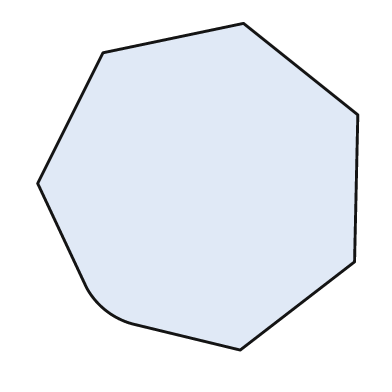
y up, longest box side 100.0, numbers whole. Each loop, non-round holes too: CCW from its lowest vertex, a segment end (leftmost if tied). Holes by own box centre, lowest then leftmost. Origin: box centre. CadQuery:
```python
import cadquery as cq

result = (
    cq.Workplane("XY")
    .moveTo(13.0, -50.0)
    .lineTo(48.0, -23.0)
    .lineTo(49.0, 22.0)
    .lineTo(14.0, 50.0)
    .lineTo(-29.0, 41.0)
    .lineTo(-49.0, 1.0)
    .lineTo(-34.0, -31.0)
    .threePointArc((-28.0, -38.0), (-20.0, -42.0))
    .close()
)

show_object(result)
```